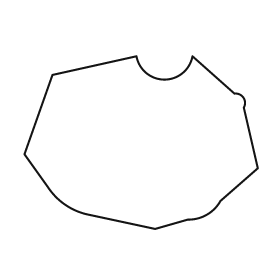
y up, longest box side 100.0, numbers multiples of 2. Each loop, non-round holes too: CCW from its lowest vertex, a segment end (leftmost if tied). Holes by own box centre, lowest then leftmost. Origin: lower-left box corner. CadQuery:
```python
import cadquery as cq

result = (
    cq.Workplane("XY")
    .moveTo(56.0, 0.0)
    .lineTo(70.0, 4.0)
    .threePointArc((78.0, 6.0), (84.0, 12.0))
    .lineTo(100.0, 26.0)
    .lineTo(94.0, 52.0)
    .threePointArc((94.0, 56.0), (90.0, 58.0))
    .lineTo(72.0, 74.0)
    .threePointArc((60.0, 64.0), (48.0, 74.0))
    .lineTo(12.0, 66.0)
    .lineTo(0.0, 32.0)
    .lineTo(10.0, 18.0)
    .threePointArc((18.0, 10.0), (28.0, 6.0))
    .close()
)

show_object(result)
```